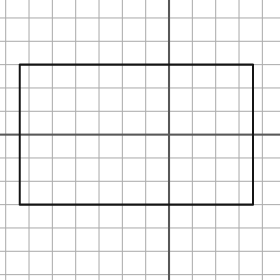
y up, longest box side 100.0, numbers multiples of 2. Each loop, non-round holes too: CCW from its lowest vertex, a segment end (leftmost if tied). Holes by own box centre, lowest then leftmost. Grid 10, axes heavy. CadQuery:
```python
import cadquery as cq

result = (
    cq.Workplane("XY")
    .moveTo(-64.0, -30.0)
    .lineTo(36.0, -30.0)
    .lineTo(36.0, 30.0)
    .lineTo(-64.0, 30.0)
    .close()
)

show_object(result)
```